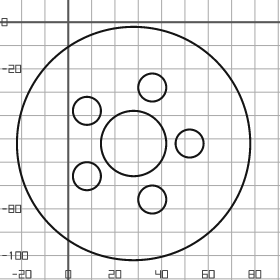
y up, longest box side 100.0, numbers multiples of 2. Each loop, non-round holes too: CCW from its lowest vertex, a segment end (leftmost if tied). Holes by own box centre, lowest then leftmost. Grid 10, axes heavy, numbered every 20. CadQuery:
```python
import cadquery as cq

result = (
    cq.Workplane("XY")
    .moveTo(28.0, -52.0)
    .circle(50.0)
    .moveTo(36.0, -76.0)
    .circle(6.0)
    .moveTo(8.0, -66.0)
    .circle(6.0)
    .moveTo(28.0, -52.0)
    .circle(14.0)
    .moveTo(52.0, -52.0)
    .circle(6.0)
    .moveTo(8.0, -38.0)
    .circle(6.0)
    .moveTo(36.0, -28.0)
    .circle(6.0)
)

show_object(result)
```